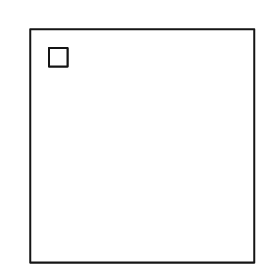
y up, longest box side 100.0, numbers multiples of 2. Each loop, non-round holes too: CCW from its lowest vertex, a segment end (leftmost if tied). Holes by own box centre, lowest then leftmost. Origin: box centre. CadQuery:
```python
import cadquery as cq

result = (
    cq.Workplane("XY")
    .moveTo(-48.0, -50.0)
    .lineTo(48.0, -50.0)
    .lineTo(48.0, 50.0)
    .lineTo(-48.0, 50.0)
    .close()
    .moveTo(-40.0, 34.0)
    .lineTo(-32.0, 34.0)
    .lineTo(-32.0, 42.0)
    .lineTo(-40.0, 42.0)
    .close()
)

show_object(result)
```